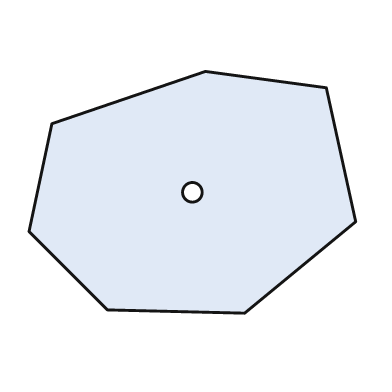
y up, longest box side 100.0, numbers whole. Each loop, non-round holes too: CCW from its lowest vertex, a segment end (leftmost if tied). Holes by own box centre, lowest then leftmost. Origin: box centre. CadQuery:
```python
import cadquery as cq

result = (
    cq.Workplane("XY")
    .moveTo(16.0, -37.0)
    .lineTo(50.0, -9.0)
    .lineTo(41.0, 32.0)
    .lineTo(4.0, 37.0)
    .lineTo(-43.0, 21.0)
    .lineTo(-50.0, -12.0)
    .lineTo(-26.0, -36.0)
    .close()
    .moveTo(0.0, 0.0)
    .circle(3.0)
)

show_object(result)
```